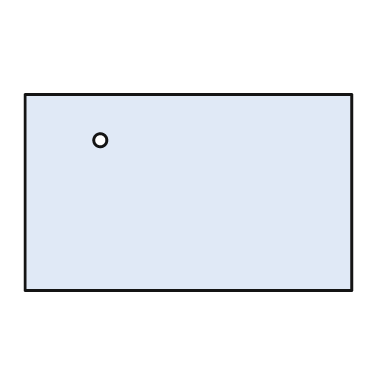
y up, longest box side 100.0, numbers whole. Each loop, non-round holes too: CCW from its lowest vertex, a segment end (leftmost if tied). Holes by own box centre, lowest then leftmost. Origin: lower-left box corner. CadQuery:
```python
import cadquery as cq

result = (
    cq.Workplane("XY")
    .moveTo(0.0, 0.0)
    .lineTo(100.0, 0.0)
    .lineTo(100.0, 60.0)
    .lineTo(0.0, 60.0)
    .close()
    .moveTo(23.0, 46.0)
    .circle(2.0)
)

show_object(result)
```